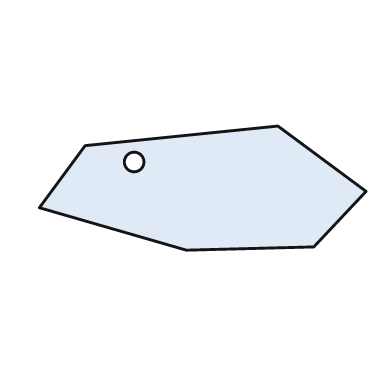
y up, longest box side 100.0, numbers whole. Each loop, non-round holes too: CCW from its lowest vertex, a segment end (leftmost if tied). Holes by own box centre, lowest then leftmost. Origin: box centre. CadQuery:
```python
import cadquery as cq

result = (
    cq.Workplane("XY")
    .moveTo(-5.0, -19.0)
    .lineTo(34.0, -18.0)
    .lineTo(50.0, -1.0)
    .lineTo(23.0, 19.0)
    .lineTo(-36.0, 13.0)
    .lineTo(-50.0, -6.0)
    .close()
    .moveTo(-21.0, 8.0)
    .circle(3.0)
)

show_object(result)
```